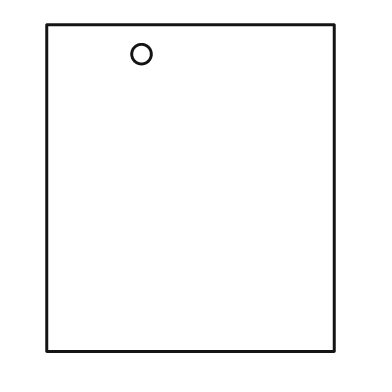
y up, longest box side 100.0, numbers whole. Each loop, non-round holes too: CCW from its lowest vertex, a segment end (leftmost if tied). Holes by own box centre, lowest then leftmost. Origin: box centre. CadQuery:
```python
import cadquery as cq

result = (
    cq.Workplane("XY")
    .moveTo(-44.0, -50.0)
    .lineTo(44.0, -50.0)
    .lineTo(44.0, 50.0)
    .lineTo(-44.0, 50.0)
    .close()
    .moveTo(-15.0, 41.0)
    .circle(3.0)
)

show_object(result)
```